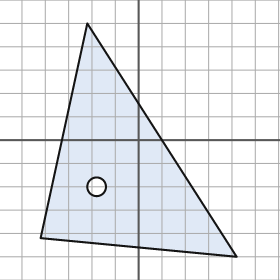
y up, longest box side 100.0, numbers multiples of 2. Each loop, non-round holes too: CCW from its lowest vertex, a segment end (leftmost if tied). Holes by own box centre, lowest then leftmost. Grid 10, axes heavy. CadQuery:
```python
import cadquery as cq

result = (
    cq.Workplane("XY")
    .moveTo(42.0, -50.0)
    .lineTo(-22.0, 50.0)
    .lineTo(-42.0, -42.0)
    .close()
    .moveTo(-18.0, -20.0)
    .circle(4.0)
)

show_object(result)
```